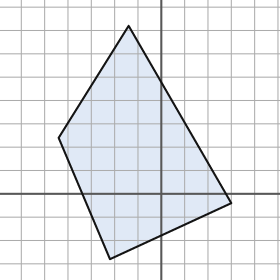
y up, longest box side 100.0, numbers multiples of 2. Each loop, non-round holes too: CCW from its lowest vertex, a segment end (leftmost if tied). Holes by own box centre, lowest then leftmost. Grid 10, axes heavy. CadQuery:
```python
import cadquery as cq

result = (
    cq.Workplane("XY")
    .moveTo(-22.0, -28.0)
    .lineTo(30.0, -4.0)
    .lineTo(-14.0, 72.0)
    .lineTo(-44.0, 24.0)
    .close()
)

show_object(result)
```